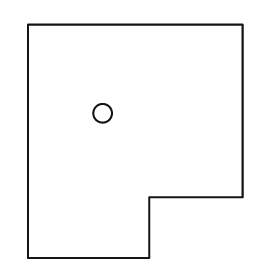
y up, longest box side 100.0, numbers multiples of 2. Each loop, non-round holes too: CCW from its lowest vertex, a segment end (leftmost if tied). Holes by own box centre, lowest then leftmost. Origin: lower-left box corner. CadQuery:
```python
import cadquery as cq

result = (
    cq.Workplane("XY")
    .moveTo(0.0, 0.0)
    .lineTo(52.0, 0.0)
    .lineTo(52.0, 26.0)
    .lineTo(92.0, 26.0)
    .lineTo(92.0, 100.0)
    .lineTo(0.0, 100.0)
    .close()
    .moveTo(32.0, 62.0)
    .circle(4.0)
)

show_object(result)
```